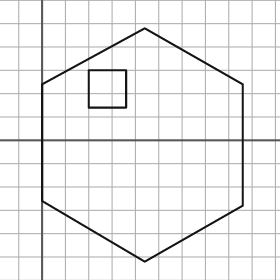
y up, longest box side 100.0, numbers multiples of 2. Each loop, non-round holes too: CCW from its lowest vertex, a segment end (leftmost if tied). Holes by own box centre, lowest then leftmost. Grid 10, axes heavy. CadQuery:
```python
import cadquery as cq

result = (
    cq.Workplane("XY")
    .moveTo(44.0, -52.0)
    .lineTo(86.0, -28.0)
    .lineTo(86.0, 24.0)
    .lineTo(44.0, 48.0)
    .lineTo(0.0, 24.0)
    .lineTo(0.0, -26.0)
    .close()
    .moveTo(20.0, 14.0)
    .lineTo(36.0, 14.0)
    .lineTo(36.0, 30.0)
    .lineTo(20.0, 30.0)
    .close()
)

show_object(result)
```